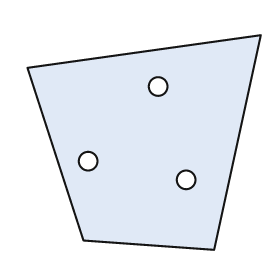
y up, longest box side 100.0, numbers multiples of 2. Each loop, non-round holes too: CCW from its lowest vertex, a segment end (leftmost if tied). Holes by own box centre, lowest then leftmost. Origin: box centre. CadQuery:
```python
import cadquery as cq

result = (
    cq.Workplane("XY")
    .moveTo(30.0, -46.0)
    .lineTo(50.0, 46.0)
    .lineTo(-50.0, 32.0)
    .lineTo(-26.0, -42.0)
    .close()
    .moveTo(18.0, -16.0)
    .circle(4.0)
    .moveTo(-24.0, -8.0)
    .circle(4.0)
    .moveTo(6.0, 24.0)
    .circle(4.0)
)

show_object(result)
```